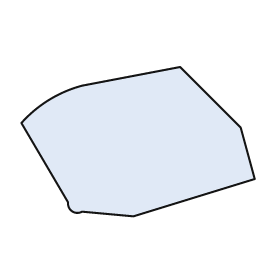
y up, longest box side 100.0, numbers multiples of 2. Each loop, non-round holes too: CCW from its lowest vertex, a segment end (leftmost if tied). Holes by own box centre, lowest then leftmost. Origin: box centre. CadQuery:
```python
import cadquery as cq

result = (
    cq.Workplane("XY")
    .moveTo(-2.0, -32.0)
    .lineTo(50.0, -16.0)
    .lineTo(44.0, 6.0)
    .lineTo(18.0, 32.0)
    .lineTo(-24.0, 24.0)
    .threePointArc((-38.0, 18.0), (-50.0, 8.0))
    .lineTo(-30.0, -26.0)
    .threePointArc((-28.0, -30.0), (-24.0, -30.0))
    .close()
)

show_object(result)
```